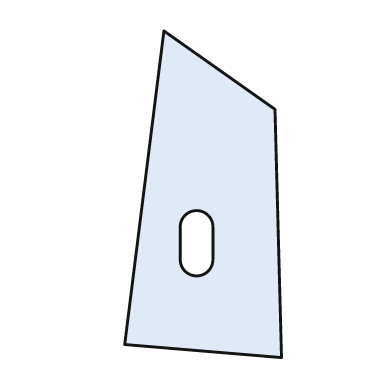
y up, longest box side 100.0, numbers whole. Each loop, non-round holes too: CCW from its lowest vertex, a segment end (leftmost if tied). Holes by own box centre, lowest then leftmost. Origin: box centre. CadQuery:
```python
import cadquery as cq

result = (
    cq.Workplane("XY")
    .moveTo(24.0, -50.0)
    .lineTo(22.0, 26.0)
    .lineTo(-12.0, 50.0)
    .lineTo(-24.0, -46.0)
    .close()
    .moveTo(-7.0, -20.0)
    .threePointArc((-2.0, -25.0), (3.0, -20.0))
    .lineTo(3.0, -10.0)
    .threePointArc((-2.0, -5.0), (-7.0, -10.0))
    .close()
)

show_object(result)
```